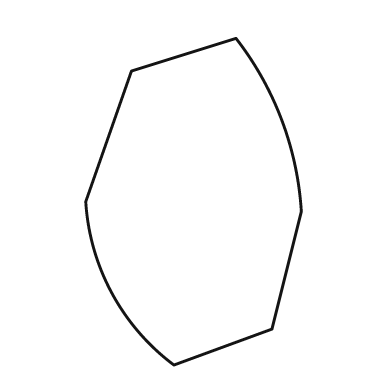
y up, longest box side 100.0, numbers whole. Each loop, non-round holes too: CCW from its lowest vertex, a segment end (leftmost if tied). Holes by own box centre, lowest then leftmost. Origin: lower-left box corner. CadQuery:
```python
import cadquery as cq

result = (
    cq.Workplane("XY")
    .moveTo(27.0, 0.0)
    .lineTo(57.0, 11.0)
    .lineTo(66.0, 47.0)
    .threePointArc((60.0, 75.0), (46.0, 100.0))
    .lineTo(14.0, 90.0)
    .lineTo(0.0, 50.0)
    .threePointArc((8.0, 22.0), (27.0, 0.0))
    .close()
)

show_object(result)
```